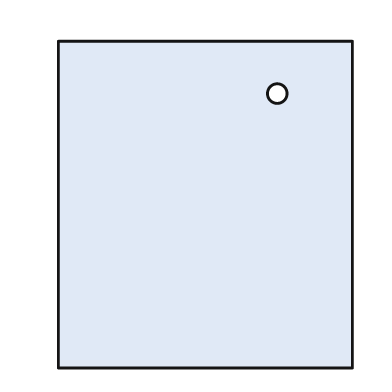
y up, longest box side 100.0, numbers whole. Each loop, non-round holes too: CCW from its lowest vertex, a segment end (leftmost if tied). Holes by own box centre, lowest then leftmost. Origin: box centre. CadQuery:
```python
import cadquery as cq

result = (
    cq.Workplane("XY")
    .moveTo(-45.0, -50.0)
    .lineTo(45.0, -50.0)
    .lineTo(45.0, 50.0)
    .lineTo(-45.0, 50.0)
    .close()
    .moveTo(22.0, 34.0)
    .circle(3.0)
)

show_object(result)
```